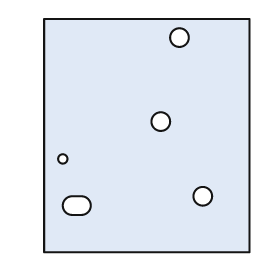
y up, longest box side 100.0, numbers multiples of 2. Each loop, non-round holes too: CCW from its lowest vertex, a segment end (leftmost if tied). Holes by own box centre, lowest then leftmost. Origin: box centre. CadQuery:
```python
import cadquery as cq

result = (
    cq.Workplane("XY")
    .moveTo(-44.0, -50.0)
    .lineTo(44.0, -50.0)
    .lineTo(44.0, 50.0)
    .lineTo(-44.0, 50.0)
    .close()
    .moveTo(-32.0, -34.0)
    .lineTo(-28.0, -34.0)
    .threePointArc((-24.0, -30.0), (-28.0, -26.0))
    .lineTo(-32.0, -26.0)
    .threePointArc((-36.0, -30.0), (-32.0, -34.0))
    .close()
    .moveTo(24.0, -26.0)
    .circle(4.0)
    .moveTo(-36.0, -10.0)
    .circle(2.0)
    .moveTo(6.0, 6.0)
    .circle(4.0)
    .moveTo(14.0, 42.0)
    .circle(4.0)
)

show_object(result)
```